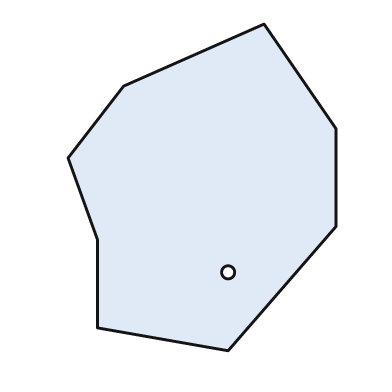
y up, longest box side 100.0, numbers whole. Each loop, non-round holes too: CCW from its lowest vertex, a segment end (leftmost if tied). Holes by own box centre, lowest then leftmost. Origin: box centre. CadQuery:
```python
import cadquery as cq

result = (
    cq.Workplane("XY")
    .moveTo(8.0, -50.0)
    .lineTo(41.0, -12.0)
    .lineTo(41.0, 18.0)
    .lineTo(19.0, 50.0)
    .lineTo(-24.0, 31.0)
    .lineTo(-41.0, 9.0)
    .lineTo(-32.0, -16.0)
    .lineTo(-32.0, -43.0)
    .close()
    .moveTo(8.0, -26.0)
    .circle(2.0)
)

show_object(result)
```